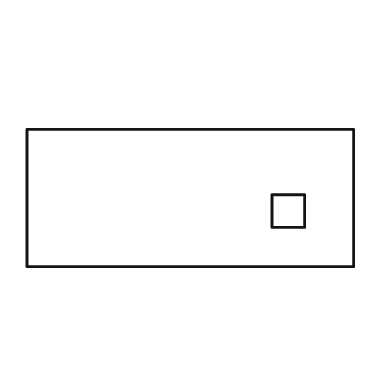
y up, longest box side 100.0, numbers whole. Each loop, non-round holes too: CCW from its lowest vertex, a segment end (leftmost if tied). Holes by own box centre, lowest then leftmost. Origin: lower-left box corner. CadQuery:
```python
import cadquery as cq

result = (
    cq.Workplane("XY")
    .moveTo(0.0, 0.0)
    .lineTo(100.0, 0.0)
    .lineTo(100.0, 42.0)
    .lineTo(0.0, 42.0)
    .close()
    .moveTo(75.0, 12.0)
    .lineTo(85.0, 12.0)
    .lineTo(85.0, 22.0)
    .lineTo(75.0, 22.0)
    .close()
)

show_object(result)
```